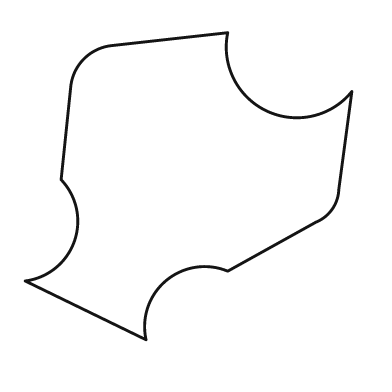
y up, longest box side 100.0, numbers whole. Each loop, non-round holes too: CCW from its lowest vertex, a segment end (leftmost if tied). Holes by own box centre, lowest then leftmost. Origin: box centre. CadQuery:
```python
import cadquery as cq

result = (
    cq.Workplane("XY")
    .moveTo(-13.0, -47.0)
    .threePointArc((-7.0, -29.0), (12.0, -26.0))
    .lineTo(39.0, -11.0)
    .threePointArc((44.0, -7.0), (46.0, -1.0))
    .lineTo(50.0, 29.0)
    .threePointArc((24.0, 23.0), (12.0, 47.0))
    .lineTo(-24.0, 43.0)
    .threePointArc((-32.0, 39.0), (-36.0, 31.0))
    .lineTo(-39.0, 2.0)
    .threePointArc((-35.0, -17.0), (-50.0, -29.0))
    .close()
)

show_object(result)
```